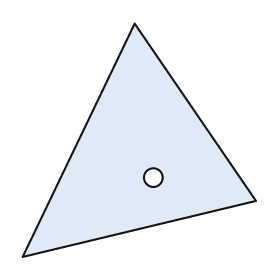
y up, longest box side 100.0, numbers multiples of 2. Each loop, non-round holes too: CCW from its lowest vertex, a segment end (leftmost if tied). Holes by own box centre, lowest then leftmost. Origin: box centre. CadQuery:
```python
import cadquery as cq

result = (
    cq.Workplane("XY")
    .moveTo(-50.0, -50.0)
    .lineTo(50.0, -26.0)
    .lineTo(-2.0, 50.0)
    .close()
    .moveTo(6.0, -16.0)
    .circle(4.0)
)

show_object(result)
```